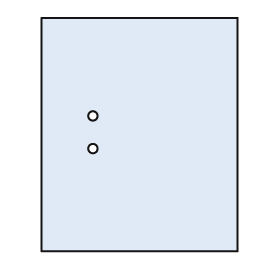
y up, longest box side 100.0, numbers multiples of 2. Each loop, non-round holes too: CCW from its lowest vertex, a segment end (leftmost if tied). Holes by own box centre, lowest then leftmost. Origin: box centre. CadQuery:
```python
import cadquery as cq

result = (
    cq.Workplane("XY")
    .moveTo(-42.0, -50.0)
    .lineTo(42.0, -50.0)
    .lineTo(42.0, 50.0)
    .lineTo(-42.0, 50.0)
    .close()
    .moveTo(-20.0, -6.0)
    .circle(2.0)
    .moveTo(-20.0, 8.0)
    .circle(2.0)
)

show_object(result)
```